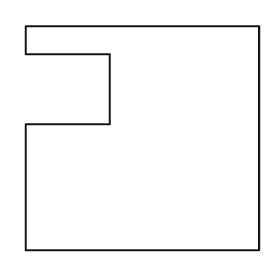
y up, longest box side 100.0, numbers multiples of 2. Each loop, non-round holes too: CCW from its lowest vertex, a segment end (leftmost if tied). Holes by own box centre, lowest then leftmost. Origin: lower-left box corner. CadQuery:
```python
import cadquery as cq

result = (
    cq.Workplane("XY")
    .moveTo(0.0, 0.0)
    .lineTo(100.0, 0.0)
    .lineTo(100.0, 96.0)
    .lineTo(0.0, 96.0)
    .lineTo(0.0, 84.0)
    .lineTo(36.0, 84.0)
    .lineTo(36.0, 54.0)
    .lineTo(0.0, 54.0)
    .close()
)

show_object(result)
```